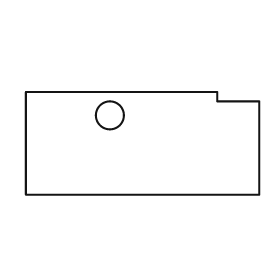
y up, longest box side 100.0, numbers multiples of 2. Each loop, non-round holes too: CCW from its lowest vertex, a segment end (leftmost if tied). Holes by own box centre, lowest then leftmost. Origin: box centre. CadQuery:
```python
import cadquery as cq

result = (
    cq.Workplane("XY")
    .moveTo(-50.0, -22.0)
    .lineTo(50.0, -22.0)
    .lineTo(50.0, 18.0)
    .lineTo(32.0, 18.0)
    .lineTo(32.0, 22.0)
    .lineTo(-50.0, 22.0)
    .close()
    .moveTo(-14.0, 12.0)
    .circle(6.0)
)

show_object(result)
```